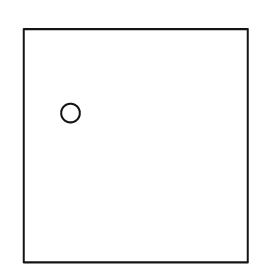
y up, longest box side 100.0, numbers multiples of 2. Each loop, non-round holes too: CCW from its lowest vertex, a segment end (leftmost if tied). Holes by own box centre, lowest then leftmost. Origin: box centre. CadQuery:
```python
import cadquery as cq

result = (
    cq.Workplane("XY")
    .moveTo(-48.0, -50.0)
    .lineTo(48.0, -50.0)
    .lineTo(48.0, 50.0)
    .lineTo(-48.0, 50.0)
    .close()
    .moveTo(-28.0, 14.0)
    .circle(4.0)
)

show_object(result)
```